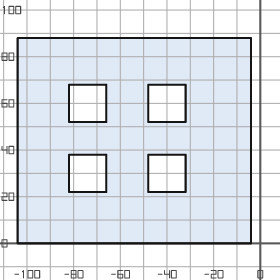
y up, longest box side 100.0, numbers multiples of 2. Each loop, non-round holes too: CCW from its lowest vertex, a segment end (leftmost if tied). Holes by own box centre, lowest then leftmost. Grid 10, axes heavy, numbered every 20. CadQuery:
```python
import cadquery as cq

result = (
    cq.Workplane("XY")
    .moveTo(-104.0, 0.0)
    .lineTo(-4.0, 0.0)
    .lineTo(-4.0, 88.0)
    .lineTo(-104.0, 88.0)
    .close()
    .moveTo(-82.0, 22.0)
    .lineTo(-66.0, 22.0)
    .lineTo(-66.0, 38.0)
    .lineTo(-82.0, 38.0)
    .close()
    .moveTo(-48.0, 22.0)
    .lineTo(-32.0, 22.0)
    .lineTo(-32.0, 38.0)
    .lineTo(-48.0, 38.0)
    .close()
    .moveTo(-82.0, 52.0)
    .lineTo(-66.0, 52.0)
    .lineTo(-66.0, 68.0)
    .lineTo(-82.0, 68.0)
    .close()
    .moveTo(-48.0, 52.0)
    .lineTo(-32.0, 52.0)
    .lineTo(-32.0, 68.0)
    .lineTo(-48.0, 68.0)
    .close()
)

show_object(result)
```